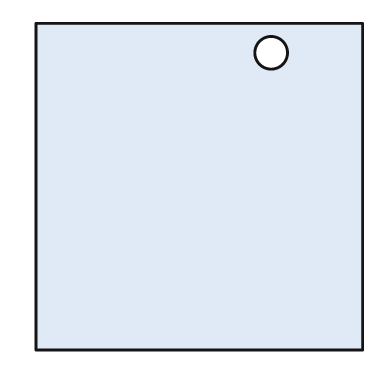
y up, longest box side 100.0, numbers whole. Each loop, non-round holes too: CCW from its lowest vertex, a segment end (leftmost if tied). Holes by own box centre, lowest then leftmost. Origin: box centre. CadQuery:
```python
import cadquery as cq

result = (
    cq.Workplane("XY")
    .moveTo(-50.0, -50.0)
    .lineTo(50.0, -50.0)
    .lineTo(50.0, 50.0)
    .lineTo(-50.0, 50.0)
    .close()
    .moveTo(22.0, 41.0)
    .circle(5.0)
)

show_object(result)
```